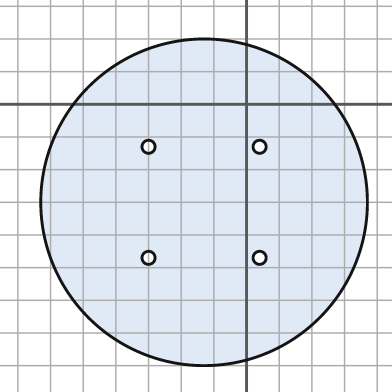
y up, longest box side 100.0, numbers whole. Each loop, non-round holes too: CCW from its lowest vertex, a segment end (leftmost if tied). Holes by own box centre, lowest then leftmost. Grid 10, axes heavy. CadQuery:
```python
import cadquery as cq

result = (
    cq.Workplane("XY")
    .moveTo(-13.0, -30.0)
    .circle(50.0)
    .moveTo(-30.0, -47.0)
    .circle(2.0)
    .moveTo(4.0, -47.0)
    .circle(2.0)
    .moveTo(-30.0, -13.0)
    .circle(2.0)
    .moveTo(4.0, -13.0)
    .circle(2.0)
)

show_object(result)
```